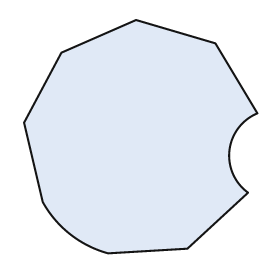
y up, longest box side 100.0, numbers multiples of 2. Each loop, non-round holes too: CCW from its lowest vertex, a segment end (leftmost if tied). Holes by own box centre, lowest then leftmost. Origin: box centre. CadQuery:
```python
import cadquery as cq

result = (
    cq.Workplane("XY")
    .moveTo(-14.0, -50.0)
    .lineTo(20.0, -48.0)
    .lineTo(46.0, -24.0)
    .threePointArc((38.0, -6.0), (50.0, 10.0))
    .lineTo(32.0, 40.0)
    .lineTo(-2.0, 50.0)
    .lineTo(-34.0, 36.0)
    .lineTo(-50.0, 6.0)
    .lineTo(-42.0, -28.0)
    .threePointArc((-30.0, -42.0), (-14.0, -50.0))
    .close()
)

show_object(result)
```